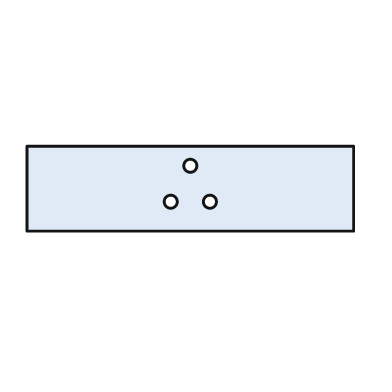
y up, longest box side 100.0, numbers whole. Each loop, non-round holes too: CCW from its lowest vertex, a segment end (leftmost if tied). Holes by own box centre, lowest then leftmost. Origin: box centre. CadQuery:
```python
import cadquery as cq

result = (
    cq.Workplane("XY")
    .moveTo(-50.0, -13.0)
    .lineTo(50.0, -13.0)
    .lineTo(50.0, 13.0)
    .lineTo(-50.0, 13.0)
    .close()
    .moveTo(-6.0, -4.0)
    .circle(2.0)
    .moveTo(6.0, -4.0)
    .circle(2.0)
    .moveTo(0.0, 7.0)
    .circle(2.0)
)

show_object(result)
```